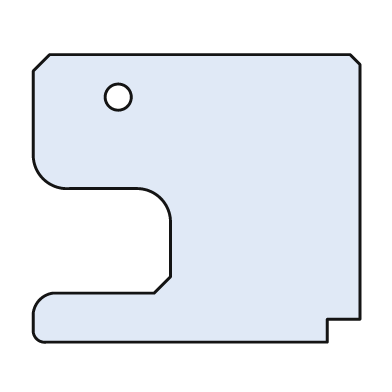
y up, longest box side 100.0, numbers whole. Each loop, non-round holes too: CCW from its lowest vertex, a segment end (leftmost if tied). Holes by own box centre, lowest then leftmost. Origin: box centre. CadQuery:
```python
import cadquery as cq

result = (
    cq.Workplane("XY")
    .moveTo(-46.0, -44.0)
    .lineTo(40.0, -44.0)
    .lineTo(40.0, -37.0)
    .lineTo(50.0, -37.0)
    .lineTo(50.0, 41.0)
    .lineTo(47.0, 44.0)
    .lineTo(-45.0, 44.0)
    .lineTo(-50.0, 39.0)
    .lineTo(-50.0, 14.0)
    .threePointArc((-47.0, 6.0), (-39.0, 3.0))
    .lineTo(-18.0, 3.0)
    .threePointArc((-11.0, 0.0), (-8.0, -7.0))
    .lineTo(-8.0, -24.0)
    .lineTo(-13.0, -29.0)
    .lineTo(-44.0, -29.0)
    .threePointArc((-48.0, -31.0), (-50.0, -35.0))
    .lineTo(-50.0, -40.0)
    .threePointArc((-49.0, -43.0), (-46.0, -44.0))
    .close()
    .moveTo(-24.0, 31.0)
    .circle(4.0)
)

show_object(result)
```